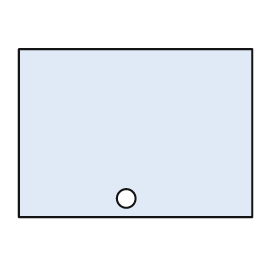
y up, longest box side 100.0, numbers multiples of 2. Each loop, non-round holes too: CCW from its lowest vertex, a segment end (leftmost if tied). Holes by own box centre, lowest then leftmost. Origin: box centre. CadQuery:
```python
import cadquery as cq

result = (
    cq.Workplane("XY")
    .moveTo(-50.0, -36.0)
    .lineTo(50.0, -36.0)
    .lineTo(50.0, 36.0)
    .lineTo(-50.0, 36.0)
    .close()
    .moveTo(-4.0, -28.0)
    .circle(4.0)
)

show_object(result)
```